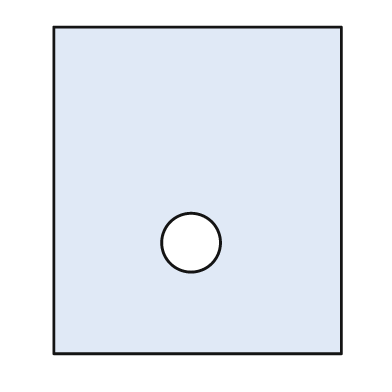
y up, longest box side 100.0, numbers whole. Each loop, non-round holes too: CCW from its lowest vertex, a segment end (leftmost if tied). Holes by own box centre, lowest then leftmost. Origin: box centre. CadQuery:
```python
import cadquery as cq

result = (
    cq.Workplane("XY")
    .moveTo(-44.0, -50.0)
    .lineTo(44.0, -50.0)
    .lineTo(44.0, 50.0)
    .lineTo(-44.0, 50.0)
    .close()
    .moveTo(-2.0, -16.0)
    .circle(9.0)
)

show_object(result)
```